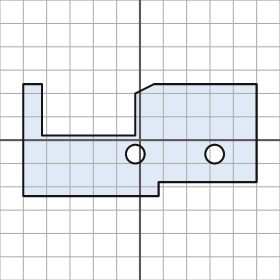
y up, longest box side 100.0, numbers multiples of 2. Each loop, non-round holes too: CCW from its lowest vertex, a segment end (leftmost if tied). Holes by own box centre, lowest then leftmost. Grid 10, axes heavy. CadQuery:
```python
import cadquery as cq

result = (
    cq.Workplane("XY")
    .moveTo(-50.0, -24.0)
    .lineTo(8.0, -24.0)
    .lineTo(8.0, -18.0)
    .lineTo(50.0, -18.0)
    .lineTo(50.0, 24.0)
    .lineTo(6.0, 24.0)
    .lineTo(-2.0, 20.0)
    .lineTo(-2.0, 2.0)
    .lineTo(-42.0, 2.0)
    .lineTo(-42.0, 24.0)
    .lineTo(-50.0, 24.0)
    .close()
    .moveTo(-2.0, -6.0)
    .circle(4.0)
    .moveTo(32.0, -6.0)
    .circle(4.0)
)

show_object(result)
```